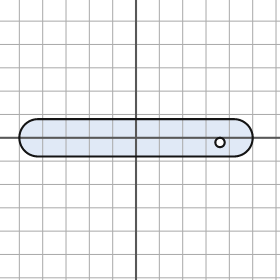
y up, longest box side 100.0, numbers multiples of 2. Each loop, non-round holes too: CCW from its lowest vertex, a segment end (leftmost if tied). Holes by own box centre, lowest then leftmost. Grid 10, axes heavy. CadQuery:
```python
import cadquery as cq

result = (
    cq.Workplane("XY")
    .moveTo(-42.0, -8.0)
    .lineTo(42.0, -8.0)
    .threePointArc((50.0, 0.0), (42.0, 8.0))
    .lineTo(-42.0, 8.0)
    .threePointArc((-50.0, 0.0), (-42.0, -8.0))
    .close()
    .moveTo(36.0, -2.0)
    .circle(2.0)
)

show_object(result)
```